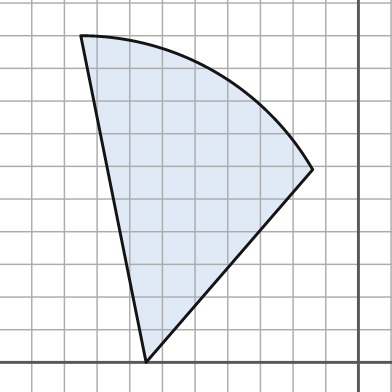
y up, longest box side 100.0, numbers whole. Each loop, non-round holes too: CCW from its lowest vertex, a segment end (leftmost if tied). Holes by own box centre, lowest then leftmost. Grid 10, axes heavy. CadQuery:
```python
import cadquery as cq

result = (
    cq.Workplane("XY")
    .moveTo(-65.0, 0.0)
    .lineTo(-14.0, 59.0)
    .threePointArc((-44.0, 89.0), (-85.0, 100.0))
    .close()
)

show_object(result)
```